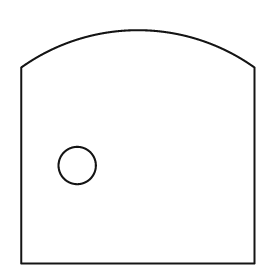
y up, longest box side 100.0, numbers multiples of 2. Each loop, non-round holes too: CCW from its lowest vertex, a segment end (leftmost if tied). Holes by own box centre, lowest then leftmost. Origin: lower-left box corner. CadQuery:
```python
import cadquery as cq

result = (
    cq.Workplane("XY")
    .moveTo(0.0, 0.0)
    .lineTo(100.0, 0.0)
    .lineTo(100.0, 84.0)
    .threePointArc((50.0, 100.0), (0.0, 84.0))
    .close()
    .moveTo(24.0, 42.0)
    .circle(8.0)
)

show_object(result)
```